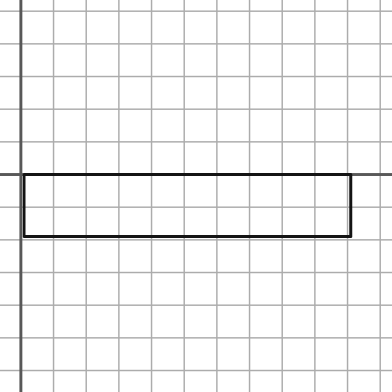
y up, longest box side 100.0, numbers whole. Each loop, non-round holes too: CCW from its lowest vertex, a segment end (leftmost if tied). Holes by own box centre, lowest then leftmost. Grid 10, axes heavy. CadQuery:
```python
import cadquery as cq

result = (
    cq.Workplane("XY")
    .moveTo(1.0, -19.0)
    .lineTo(101.0, -19.0)
    .lineTo(101.0, 0.0)
    .lineTo(1.0, 0.0)
    .close()
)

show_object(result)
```